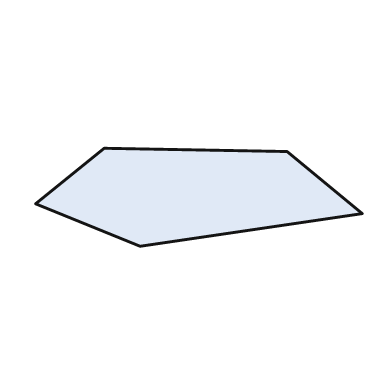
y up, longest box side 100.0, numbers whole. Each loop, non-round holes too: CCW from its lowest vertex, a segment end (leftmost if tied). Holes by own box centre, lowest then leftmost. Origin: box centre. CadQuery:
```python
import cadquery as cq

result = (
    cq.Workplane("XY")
    .moveTo(-18.0, -15.0)
    .lineTo(50.0, -5.0)
    .lineTo(27.0, 14.0)
    .lineTo(-29.0, 15.0)
    .lineTo(-50.0, -2.0)
    .close()
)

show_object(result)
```